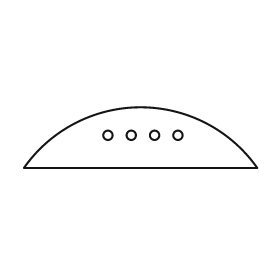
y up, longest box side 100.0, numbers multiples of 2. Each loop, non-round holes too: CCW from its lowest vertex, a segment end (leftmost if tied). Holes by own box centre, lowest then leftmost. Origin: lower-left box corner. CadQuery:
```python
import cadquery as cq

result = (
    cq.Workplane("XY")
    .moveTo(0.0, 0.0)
    .lineTo(100.0, 0.0)
    .threePointArc((50.0, 26.0), (0.0, 0.0))
    .close()
    .moveTo(36.0, 14.0)
    .circle(2.0)
    .moveTo(46.0, 14.0)
    .circle(2.0)
    .moveTo(56.0, 14.0)
    .circle(2.0)
    .moveTo(66.0, 14.0)
    .circle(2.0)
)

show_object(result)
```